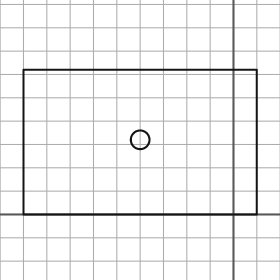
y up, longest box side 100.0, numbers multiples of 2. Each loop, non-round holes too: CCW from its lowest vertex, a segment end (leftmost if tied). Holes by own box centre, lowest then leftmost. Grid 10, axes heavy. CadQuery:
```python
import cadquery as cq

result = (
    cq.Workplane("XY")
    .moveTo(-90.0, 0.0)
    .lineTo(10.0, 0.0)
    .lineTo(10.0, 62.0)
    .lineTo(-90.0, 62.0)
    .close()
    .moveTo(-40.0, 32.0)
    .circle(4.0)
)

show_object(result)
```